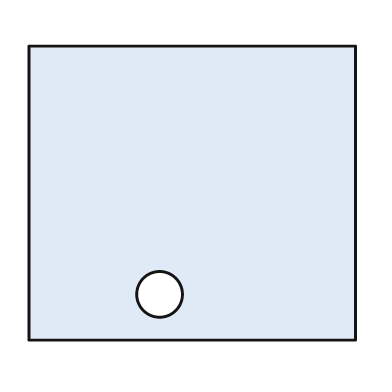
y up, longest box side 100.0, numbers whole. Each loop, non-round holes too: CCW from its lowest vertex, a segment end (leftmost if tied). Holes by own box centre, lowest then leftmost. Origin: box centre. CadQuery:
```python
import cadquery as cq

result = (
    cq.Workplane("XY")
    .moveTo(-50.0, -45.0)
    .lineTo(50.0, -45.0)
    .lineTo(50.0, 45.0)
    .lineTo(-50.0, 45.0)
    .close()
    .moveTo(-10.0, -31.0)
    .circle(7.0)
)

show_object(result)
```